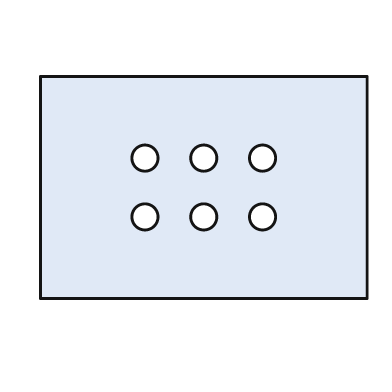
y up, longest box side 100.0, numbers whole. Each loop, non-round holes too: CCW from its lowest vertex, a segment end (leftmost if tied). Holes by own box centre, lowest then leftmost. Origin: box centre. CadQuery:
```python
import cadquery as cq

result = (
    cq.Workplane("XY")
    .moveTo(-50.0, -34.0)
    .lineTo(50.0, -34.0)
    .lineTo(50.0, 34.0)
    .lineTo(-50.0, 34.0)
    .close()
    .moveTo(-18.0, -9.0)
    .circle(4.0)
    .moveTo(0.0, -9.0)
    .circle(4.0)
    .moveTo(18.0, -9.0)
    .circle(4.0)
    .moveTo(-18.0, 9.0)
    .circle(4.0)
    .moveTo(0.0, 9.0)
    .circle(4.0)
    .moveTo(18.0, 9.0)
    .circle(4.0)
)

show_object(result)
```